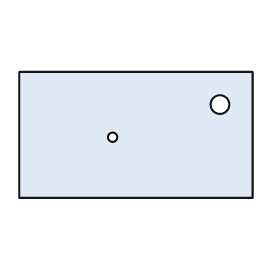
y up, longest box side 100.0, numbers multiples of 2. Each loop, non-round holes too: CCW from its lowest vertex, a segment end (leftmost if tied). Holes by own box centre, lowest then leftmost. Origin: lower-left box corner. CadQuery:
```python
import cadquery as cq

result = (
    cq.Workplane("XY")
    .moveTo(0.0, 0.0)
    .lineTo(100.0, 0.0)
    .lineTo(100.0, 54.0)
    .lineTo(0.0, 54.0)
    .close()
    .moveTo(40.0, 26.0)
    .circle(2.0)
    .moveTo(86.0, 40.0)
    .circle(4.0)
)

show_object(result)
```